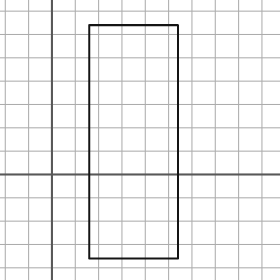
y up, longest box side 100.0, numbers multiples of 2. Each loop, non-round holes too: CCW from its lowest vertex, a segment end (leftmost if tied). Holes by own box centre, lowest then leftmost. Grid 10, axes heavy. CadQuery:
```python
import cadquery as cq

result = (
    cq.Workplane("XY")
    .moveTo(16.0, -36.0)
    .lineTo(54.0, -36.0)
    .lineTo(54.0, 64.0)
    .lineTo(16.0, 64.0)
    .close()
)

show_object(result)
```